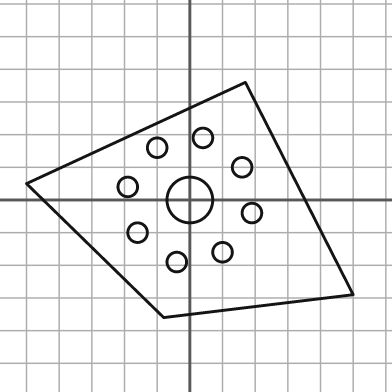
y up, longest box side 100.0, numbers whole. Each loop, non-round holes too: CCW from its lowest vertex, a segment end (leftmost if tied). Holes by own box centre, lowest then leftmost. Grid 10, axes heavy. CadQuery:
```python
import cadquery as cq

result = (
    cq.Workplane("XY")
    .moveTo(-8.0, -36.0)
    .lineTo(50.0, -29.0)
    .lineTo(17.0, 36.0)
    .lineTo(-50.0, 5.0)
    .close()
    .moveTo(-4.0, -19.0)
    .circle(3.0)
    .moveTo(10.0, -16.0)
    .circle(3.0)
    .moveTo(-16.0, -10.0)
    .circle(3.0)
    .moveTo(19.0, -4.0)
    .circle(3.0)
    .moveTo(0.0, 0.0)
    .circle(7.0)
    .moveTo(-19.0, 4.0)
    .circle(3.0)
    .moveTo(16.0, 10.0)
    .circle(3.0)
    .moveTo(-10.0, 16.0)
    .circle(3.0)
    .moveTo(4.0, 19.0)
    .circle(3.0)
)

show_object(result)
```